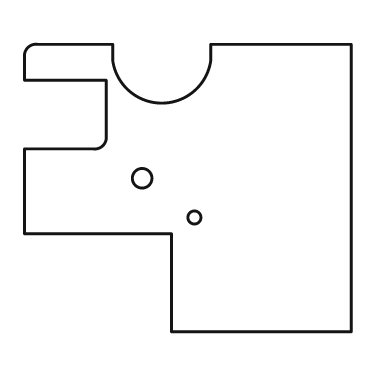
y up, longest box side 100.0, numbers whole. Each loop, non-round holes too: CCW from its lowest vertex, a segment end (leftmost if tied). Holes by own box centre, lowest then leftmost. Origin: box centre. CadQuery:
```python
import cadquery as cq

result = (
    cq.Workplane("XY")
    .moveTo(-5.0, -44.0)
    .lineTo(50.0, -44.0)
    .lineTo(50.0, 44.0)
    .lineTo(7.0, 44.0)
    .lineTo(7.0, 39.0)
    .threePointArc((-8.0, 26.0), (-23.0, 39.0))
    .lineTo(-23.0, 44.0)
    .lineTo(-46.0, 44.0)
    .threePointArc((-49.0, 43.0), (-50.0, 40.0))
    .lineTo(-50.0, 33.0)
    .lineTo(-25.0, 33.0)
    .lineTo(-25.0, 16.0)
    .threePointArc((-26.0, 13.0), (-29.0, 12.0))
    .lineTo(-50.0, 12.0)
    .lineTo(-50.0, -14.0)
    .lineTo(-5.0, -14.0)
    .close()
    .moveTo(2.0, -9.0)
    .circle(2.0)
    .moveTo(-14.0, 3.0)
    .circle(3.0)
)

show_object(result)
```